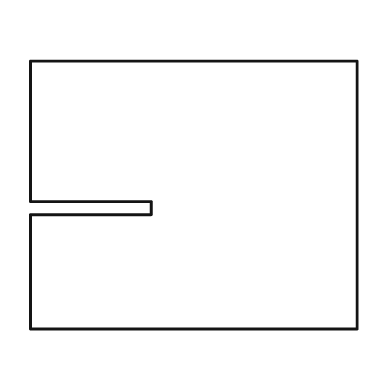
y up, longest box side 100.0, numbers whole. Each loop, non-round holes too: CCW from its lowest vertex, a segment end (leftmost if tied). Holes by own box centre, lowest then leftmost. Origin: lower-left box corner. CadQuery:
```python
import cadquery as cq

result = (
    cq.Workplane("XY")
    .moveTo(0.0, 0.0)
    .lineTo(100.0, 0.0)
    .lineTo(100.0, 82.0)
    .lineTo(0.0, 82.0)
    .lineTo(0.0, 39.0)
    .lineTo(37.0, 39.0)
    .lineTo(37.0, 35.0)
    .lineTo(0.0, 35.0)
    .close()
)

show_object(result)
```